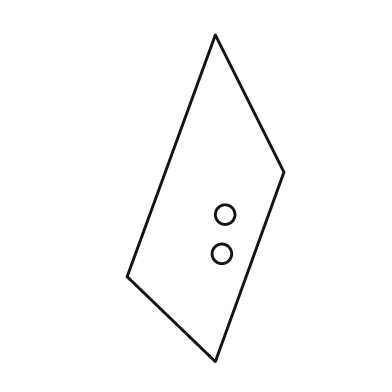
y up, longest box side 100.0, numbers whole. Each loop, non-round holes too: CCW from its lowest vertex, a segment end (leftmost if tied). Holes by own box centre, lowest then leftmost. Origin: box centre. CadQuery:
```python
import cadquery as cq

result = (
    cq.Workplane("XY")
    .moveTo(3.0, -50.0)
    .lineTo(24.0, 8.0)
    .lineTo(3.0, 50.0)
    .lineTo(-24.0, -24.0)
    .close()
    .moveTo(5.0, -17.0)
    .circle(3.0)
    .moveTo(6.0, -5.0)
    .circle(3.0)
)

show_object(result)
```